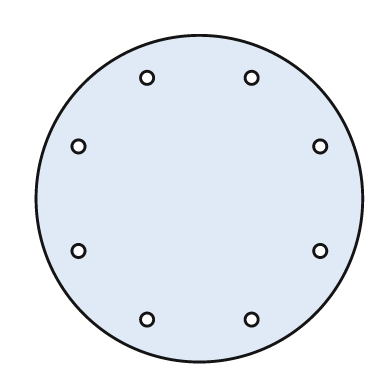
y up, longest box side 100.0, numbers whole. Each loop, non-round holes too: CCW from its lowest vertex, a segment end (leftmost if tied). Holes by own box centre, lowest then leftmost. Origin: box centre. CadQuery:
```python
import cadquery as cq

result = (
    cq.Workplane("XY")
    .moveTo(0.0, 0.0)
    .circle(50.0)
    .moveTo(-16.0, -37.0)
    .circle(2.0)
    .moveTo(16.0, -37.0)
    .circle(2.0)
    .moveTo(-37.0, -16.0)
    .circle(2.0)
    .moveTo(37.0, -16.0)
    .circle(2.0)
    .moveTo(-37.0, 16.0)
    .circle(2.0)
    .moveTo(37.0, 16.0)
    .circle(2.0)
    .moveTo(-16.0, 37.0)
    .circle(2.0)
    .moveTo(16.0, 37.0)
    .circle(2.0)
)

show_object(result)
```